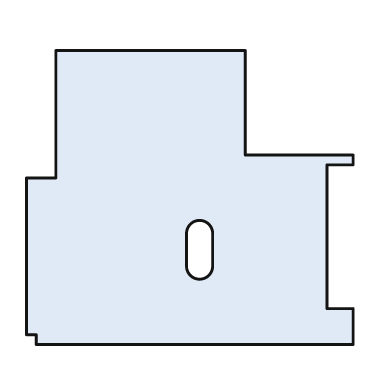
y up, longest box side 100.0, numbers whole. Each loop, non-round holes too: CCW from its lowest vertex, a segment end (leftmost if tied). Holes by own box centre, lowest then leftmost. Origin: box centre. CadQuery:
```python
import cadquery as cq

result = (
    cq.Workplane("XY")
    .moveTo(-47.0, -45.0)
    .lineTo(50.0, -45.0)
    .lineTo(50.0, -34.0)
    .lineTo(42.0, -34.0)
    .lineTo(42.0, 10.0)
    .lineTo(50.0, 10.0)
    .lineTo(50.0, 13.0)
    .lineTo(17.0, 13.0)
    .lineTo(17.0, 45.0)
    .lineTo(-41.0, 45.0)
    .lineTo(-41.0, 6.0)
    .lineTo(-50.0, 6.0)
    .lineTo(-50.0, -42.0)
    .lineTo(-47.0, -42.0)
    .close()
    .moveTo(-1.0, -21.0)
    .threePointArc((3.0, -25.0), (7.0, -21.0))
    .lineTo(7.0, -11.0)
    .threePointArc((3.0, -7.0), (-1.0, -11.0))
    .close()
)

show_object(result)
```